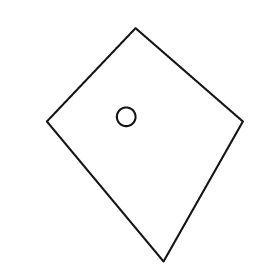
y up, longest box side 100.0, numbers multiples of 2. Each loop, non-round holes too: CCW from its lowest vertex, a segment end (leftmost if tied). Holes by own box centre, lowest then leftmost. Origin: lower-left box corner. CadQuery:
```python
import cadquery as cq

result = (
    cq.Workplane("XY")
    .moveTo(50.0, 0.0)
    .lineTo(84.0, 60.0)
    .lineTo(38.0, 100.0)
    .lineTo(0.0, 60.0)
    .close()
    .moveTo(34.0, 62.0)
    .circle(4.0)
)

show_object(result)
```